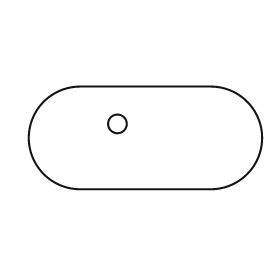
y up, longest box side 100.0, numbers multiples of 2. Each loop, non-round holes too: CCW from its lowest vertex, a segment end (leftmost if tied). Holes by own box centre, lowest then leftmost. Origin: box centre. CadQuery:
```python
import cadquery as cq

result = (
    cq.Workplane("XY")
    .moveTo(-28.0, -22.0)
    .lineTo(28.0, -22.0)
    .threePointArc((50.0, 0.0), (28.0, 22.0))
    .lineTo(-28.0, 22.0)
    .threePointArc((-50.0, 0.0), (-28.0, -22.0))
    .close()
    .moveTo(-12.0, 6.0)
    .circle(4.0)
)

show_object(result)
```